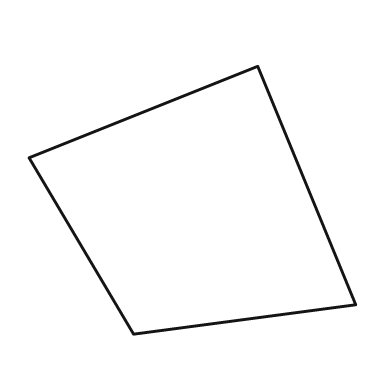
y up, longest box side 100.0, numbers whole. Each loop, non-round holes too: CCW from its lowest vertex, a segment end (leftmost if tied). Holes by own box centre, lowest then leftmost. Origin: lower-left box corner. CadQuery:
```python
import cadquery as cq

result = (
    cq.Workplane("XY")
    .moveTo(32.0, 0.0)
    .lineTo(100.0, 9.0)
    .lineTo(70.0, 82.0)
    .lineTo(0.0, 54.0)
    .close()
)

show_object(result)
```